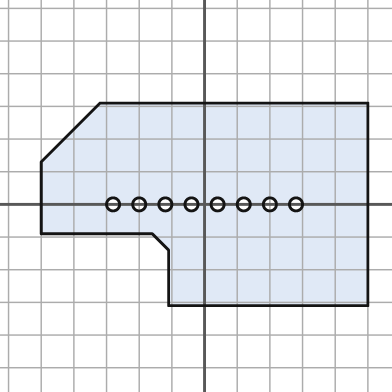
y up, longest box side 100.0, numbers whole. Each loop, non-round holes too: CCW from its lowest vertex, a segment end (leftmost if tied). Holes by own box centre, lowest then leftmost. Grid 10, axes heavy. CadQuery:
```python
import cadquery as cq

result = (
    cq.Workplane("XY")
    .moveTo(-11.0, -31.0)
    .lineTo(50.0, -31.0)
    .lineTo(50.0, 31.0)
    .lineTo(-32.0, 31.0)
    .lineTo(-50.0, 13.0)
    .lineTo(-50.0, -9.0)
    .lineTo(-16.0, -9.0)
    .lineTo(-11.0, -14.0)
    .close()
    .moveTo(-28.0, 0.0)
    .circle(2.0)
    .moveTo(-20.0, 0.0)
    .circle(2.0)
    .moveTo(-12.0, 0.0)
    .circle(2.0)
    .moveTo(-4.0, 0.0)
    .circle(2.0)
    .moveTo(4.0, 0.0)
    .circle(2.0)
    .moveTo(12.0, 0.0)
    .circle(2.0)
    .moveTo(20.0, 0.0)
    .circle(2.0)
    .moveTo(28.0, 0.0)
    .circle(2.0)
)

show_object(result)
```